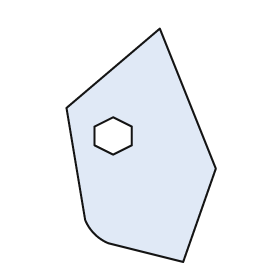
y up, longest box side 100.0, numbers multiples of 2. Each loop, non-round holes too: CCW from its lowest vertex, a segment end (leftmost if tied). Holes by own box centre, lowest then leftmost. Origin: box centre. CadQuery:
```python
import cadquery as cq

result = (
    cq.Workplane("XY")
    .moveTo(18.0, -50.0)
    .lineTo(32.0, -10.0)
    .lineTo(8.0, 50.0)
    .lineTo(-32.0, 16.0)
    .lineTo(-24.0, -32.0)
    .threePointArc((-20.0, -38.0), (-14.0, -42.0))
    .close()
    .moveTo(-12.0, -4.0)
    .lineTo(-4.0, 0.0)
    .lineTo(-4.0, 8.0)
    .lineTo(-12.0, 12.0)
    .lineTo(-20.0, 8.0)
    .lineTo(-20.0, 0.0)
    .close()
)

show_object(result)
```